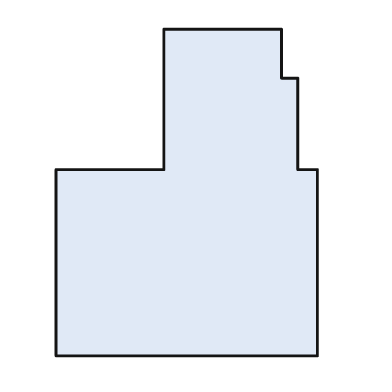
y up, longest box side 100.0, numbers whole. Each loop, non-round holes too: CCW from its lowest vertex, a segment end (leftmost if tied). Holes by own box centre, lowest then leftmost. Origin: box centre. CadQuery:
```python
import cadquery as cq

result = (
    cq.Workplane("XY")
    .moveTo(-40.0, -50.0)
    .lineTo(40.0, -50.0)
    .lineTo(40.0, 7.0)
    .lineTo(34.0, 7.0)
    .lineTo(34.0, 35.0)
    .lineTo(29.0, 35.0)
    .lineTo(29.0, 50.0)
    .lineTo(-7.0, 50.0)
    .lineTo(-7.0, 7.0)
    .lineTo(-40.0, 7.0)
    .close()
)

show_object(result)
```